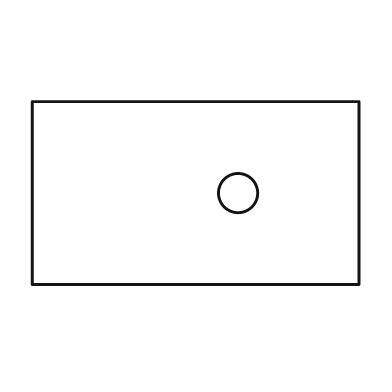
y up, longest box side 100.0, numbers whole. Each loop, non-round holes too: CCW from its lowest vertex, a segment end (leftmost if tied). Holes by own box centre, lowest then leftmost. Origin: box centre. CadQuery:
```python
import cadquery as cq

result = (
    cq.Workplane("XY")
    .moveTo(-50.0, -28.0)
    .lineTo(50.0, -28.0)
    .lineTo(50.0, 28.0)
    .lineTo(-50.0, 28.0)
    .close()
    .moveTo(13.0, 0.0)
    .circle(6.0)
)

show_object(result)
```